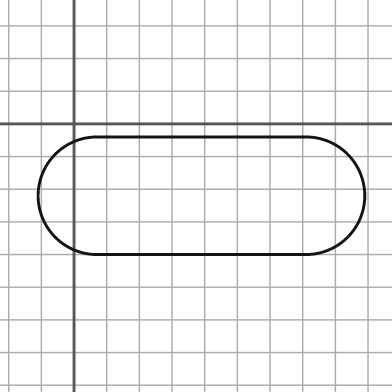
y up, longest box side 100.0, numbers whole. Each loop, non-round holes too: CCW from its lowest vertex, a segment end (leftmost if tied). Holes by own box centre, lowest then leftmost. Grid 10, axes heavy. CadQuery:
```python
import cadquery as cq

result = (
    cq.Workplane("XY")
    .moveTo(7.0, -40.0)
    .lineTo(71.0, -40.0)
    .threePointArc((89.0, -22.0), (71.0, -4.0))
    .lineTo(7.0, -4.0)
    .threePointArc((-11.0, -22.0), (7.0, -40.0))
    .close()
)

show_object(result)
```